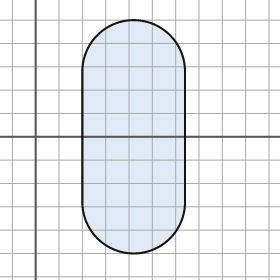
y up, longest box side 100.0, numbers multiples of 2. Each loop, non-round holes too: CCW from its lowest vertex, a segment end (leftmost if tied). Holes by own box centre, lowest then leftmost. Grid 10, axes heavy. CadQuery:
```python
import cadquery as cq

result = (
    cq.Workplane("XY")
    .moveTo(20.0, -28.0)
    .threePointArc((42.0, -50.0), (64.0, -28.0))
    .lineTo(64.0, 28.0)
    .threePointArc((42.0, 50.0), (20.0, 28.0))
    .close()
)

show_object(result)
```